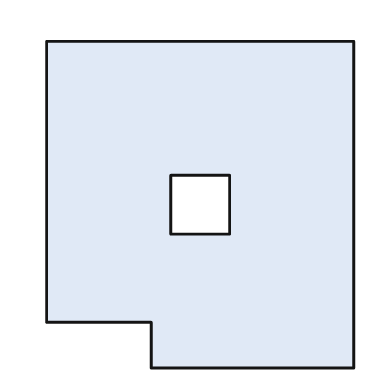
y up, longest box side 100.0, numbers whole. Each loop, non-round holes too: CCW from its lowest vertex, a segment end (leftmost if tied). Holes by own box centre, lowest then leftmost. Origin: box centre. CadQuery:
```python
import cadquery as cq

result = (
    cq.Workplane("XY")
    .moveTo(-15.0, -50.0)
    .lineTo(47.0, -50.0)
    .lineTo(47.0, 50.0)
    .lineTo(-47.0, 50.0)
    .lineTo(-47.0, -36.0)
    .lineTo(-15.0, -36.0)
    .close()
    .moveTo(-9.0, -9.0)
    .lineTo(9.0, -9.0)
    .lineTo(9.0, 9.0)
    .lineTo(-9.0, 9.0)
    .close()
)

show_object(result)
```